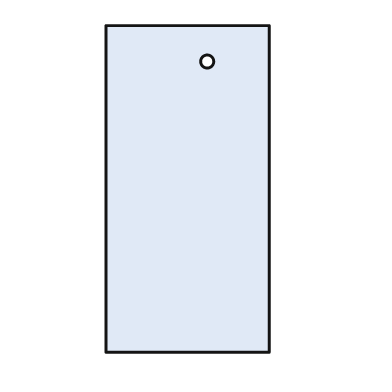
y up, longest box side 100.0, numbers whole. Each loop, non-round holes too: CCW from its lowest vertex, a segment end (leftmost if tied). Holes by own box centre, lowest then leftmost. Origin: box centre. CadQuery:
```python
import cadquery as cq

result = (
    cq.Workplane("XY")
    .moveTo(-25.0, -50.0)
    .lineTo(25.0, -50.0)
    .lineTo(25.0, 50.0)
    .lineTo(-25.0, 50.0)
    .close()
    .moveTo(6.0, 39.0)
    .circle(2.0)
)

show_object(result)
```